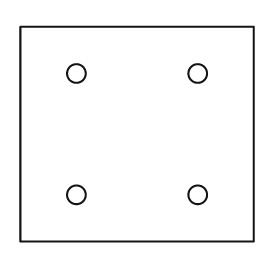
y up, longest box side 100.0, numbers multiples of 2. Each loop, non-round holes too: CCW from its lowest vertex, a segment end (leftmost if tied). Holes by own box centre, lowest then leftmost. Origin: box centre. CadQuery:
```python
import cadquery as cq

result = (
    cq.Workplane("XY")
    .moveTo(-50.0, -46.0)
    .lineTo(50.0, -46.0)
    .lineTo(50.0, 46.0)
    .lineTo(-50.0, 46.0)
    .close()
    .moveTo(-26.0, -26.0)
    .circle(4.0)
    .moveTo(26.0, -26.0)
    .circle(4.0)
    .moveTo(-26.0, 26.0)
    .circle(4.0)
    .moveTo(26.0, 26.0)
    .circle(4.0)
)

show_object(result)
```